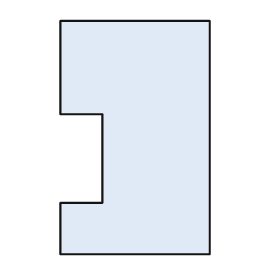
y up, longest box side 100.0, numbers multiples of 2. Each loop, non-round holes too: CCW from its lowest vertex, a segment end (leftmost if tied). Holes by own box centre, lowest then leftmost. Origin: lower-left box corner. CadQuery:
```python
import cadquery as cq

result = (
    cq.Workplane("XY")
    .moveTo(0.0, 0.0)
    .lineTo(64.0, 0.0)
    .lineTo(64.0, 100.0)
    .lineTo(0.0, 100.0)
    .lineTo(0.0, 60.0)
    .lineTo(18.0, 60.0)
    .lineTo(18.0, 22.0)
    .lineTo(0.0, 22.0)
    .close()
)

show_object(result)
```